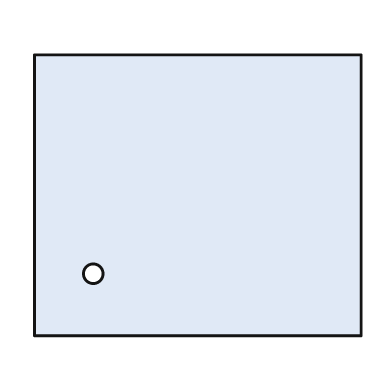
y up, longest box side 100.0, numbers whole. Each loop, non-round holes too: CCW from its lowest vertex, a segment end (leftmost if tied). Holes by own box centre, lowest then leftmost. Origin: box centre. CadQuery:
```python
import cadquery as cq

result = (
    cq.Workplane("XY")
    .moveTo(-50.0, -43.0)
    .lineTo(50.0, -43.0)
    .lineTo(50.0, 43.0)
    .lineTo(-50.0, 43.0)
    .close()
    .moveTo(-32.0, -24.0)
    .circle(3.0)
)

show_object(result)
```